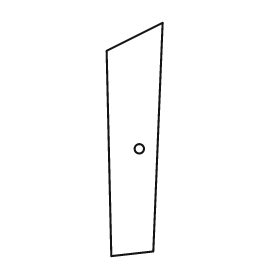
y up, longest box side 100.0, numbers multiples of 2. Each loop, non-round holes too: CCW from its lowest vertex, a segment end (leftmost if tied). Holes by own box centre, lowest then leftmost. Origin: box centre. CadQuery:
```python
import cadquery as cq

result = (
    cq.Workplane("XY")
    .moveTo(-10.0, -50.0)
    .lineTo(8.0, -48.0)
    .lineTo(12.0, 50.0)
    .lineTo(-12.0, 38.0)
    .close()
    .moveTo(2.0, -4.0)
    .circle(2.0)
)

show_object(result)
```